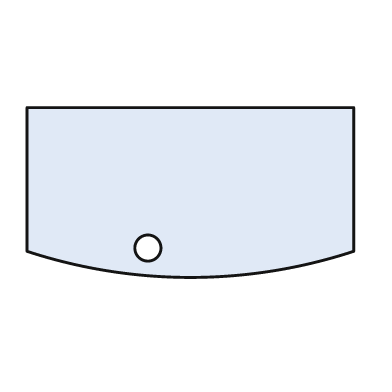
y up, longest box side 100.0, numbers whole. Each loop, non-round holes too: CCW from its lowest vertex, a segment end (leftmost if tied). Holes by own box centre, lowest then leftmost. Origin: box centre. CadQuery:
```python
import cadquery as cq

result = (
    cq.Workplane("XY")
    .moveTo(-50.0, -18.0)
    .threePointArc((0.0, -26.0), (50.0, -18.0))
    .lineTo(50.0, 26.0)
    .lineTo(-50.0, 26.0)
    .close()
    .moveTo(-13.0, -17.0)
    .circle(4.0)
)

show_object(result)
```